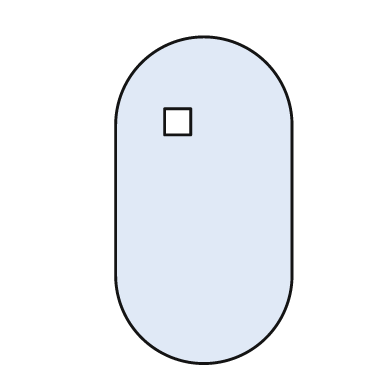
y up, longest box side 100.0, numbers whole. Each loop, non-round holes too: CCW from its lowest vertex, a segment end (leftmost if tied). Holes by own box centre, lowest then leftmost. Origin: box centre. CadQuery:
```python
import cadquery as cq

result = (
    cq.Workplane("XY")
    .moveTo(-27.0, -23.0)
    .threePointArc((0.0, -50.0), (27.0, -23.0))
    .lineTo(27.0, 23.0)
    .threePointArc((0.0, 50.0), (-27.0, 23.0))
    .close()
    .moveTo(-12.0, 20.0)
    .lineTo(-4.0, 20.0)
    .lineTo(-4.0, 28.0)
    .lineTo(-12.0, 28.0)
    .close()
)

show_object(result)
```